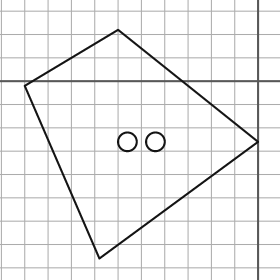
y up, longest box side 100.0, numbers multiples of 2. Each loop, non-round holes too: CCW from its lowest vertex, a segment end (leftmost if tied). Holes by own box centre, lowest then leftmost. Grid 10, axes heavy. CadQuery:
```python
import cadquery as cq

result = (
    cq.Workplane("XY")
    .moveTo(-68.0, -76.0)
    .lineTo(0.0, -26.0)
    .lineTo(-60.0, 22.0)
    .lineTo(-100.0, -2.0)
    .close()
    .moveTo(-56.0, -26.0)
    .circle(4.0)
    .moveTo(-44.0, -26.0)
    .circle(4.0)
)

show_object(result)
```